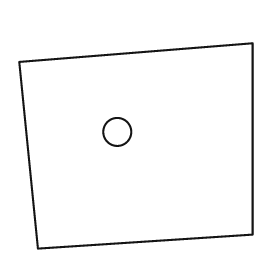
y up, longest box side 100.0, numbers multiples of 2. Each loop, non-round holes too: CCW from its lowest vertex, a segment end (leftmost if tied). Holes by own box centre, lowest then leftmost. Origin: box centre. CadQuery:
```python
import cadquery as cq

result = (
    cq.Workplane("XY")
    .moveTo(-42.0, -44.0)
    .lineTo(50.0, -38.0)
    .lineTo(50.0, 44.0)
    .lineTo(-50.0, 36.0)
    .close()
    .moveTo(-8.0, 6.0)
    .circle(6.0)
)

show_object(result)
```